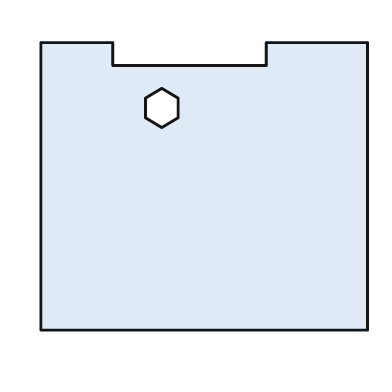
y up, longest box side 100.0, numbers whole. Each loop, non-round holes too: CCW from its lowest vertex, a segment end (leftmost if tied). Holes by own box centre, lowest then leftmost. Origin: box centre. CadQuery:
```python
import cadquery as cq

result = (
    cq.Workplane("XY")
    .moveTo(-50.0, -44.0)
    .lineTo(50.0, -44.0)
    .lineTo(50.0, 44.0)
    .lineTo(19.0, 44.0)
    .lineTo(19.0, 37.0)
    .lineTo(-28.0, 37.0)
    .lineTo(-28.0, 44.0)
    .lineTo(-50.0, 44.0)
    .close()
    .moveTo(-13.0, 18.0)
    .lineTo(-8.0, 21.0)
    .lineTo(-8.0, 27.0)
    .lineTo(-13.0, 30.0)
    .lineTo(-18.0, 27.0)
    .lineTo(-18.0, 21.0)
    .close()
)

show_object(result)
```